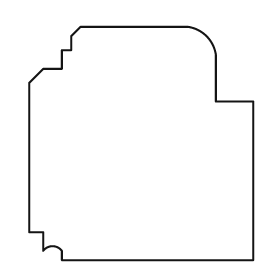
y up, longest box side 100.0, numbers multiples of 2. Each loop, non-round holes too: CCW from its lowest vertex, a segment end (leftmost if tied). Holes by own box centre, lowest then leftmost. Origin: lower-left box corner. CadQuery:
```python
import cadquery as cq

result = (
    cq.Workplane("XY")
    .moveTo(14.0, 0.0)
    .lineTo(96.0, 0.0)
    .lineTo(96.0, 68.0)
    .lineTo(80.0, 68.0)
    .lineTo(80.0, 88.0)
    .threePointArc((76.0, 96.0), (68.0, 100.0))
    .lineTo(22.0, 100.0)
    .lineTo(18.0, 96.0)
    .lineTo(18.0, 90.0)
    .lineTo(14.0, 90.0)
    .lineTo(14.0, 82.0)
    .lineTo(6.0, 82.0)
    .lineTo(0.0, 76.0)
    .lineTo(0.0, 12.0)
    .lineTo(6.0, 12.0)
    .lineTo(6.0, 4.0)
    .threePointArc((10.0, 6.0), (14.0, 4.0))
    .close()
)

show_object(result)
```